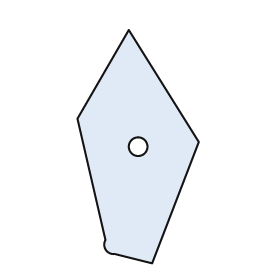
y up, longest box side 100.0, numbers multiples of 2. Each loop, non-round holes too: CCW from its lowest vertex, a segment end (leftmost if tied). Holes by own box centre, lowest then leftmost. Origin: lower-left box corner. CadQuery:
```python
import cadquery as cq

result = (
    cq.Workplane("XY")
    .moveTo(32.0, 0.0)
    .lineTo(52.0, 52.0)
    .lineTo(22.0, 100.0)
    .lineTo(0.0, 62.0)
    .lineTo(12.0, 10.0)
    .threePointArc((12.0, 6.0), (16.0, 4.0))
    .close()
    .moveTo(26.0, 50.0)
    .circle(4.0)
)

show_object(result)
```